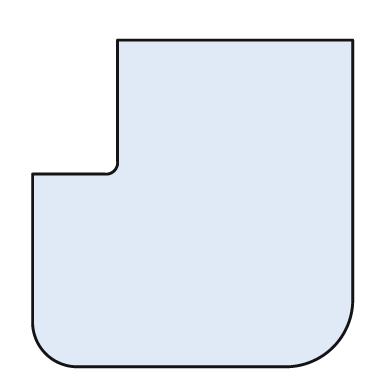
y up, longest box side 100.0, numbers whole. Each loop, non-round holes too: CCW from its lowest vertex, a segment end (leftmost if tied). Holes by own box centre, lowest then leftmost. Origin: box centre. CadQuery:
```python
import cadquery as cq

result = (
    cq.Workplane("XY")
    .moveTo(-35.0, -50.0)
    .lineTo(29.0, -50.0)
    .threePointArc((43.0, -44.0), (49.0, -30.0))
    .lineTo(49.0, 50.0)
    .lineTo(-23.0, 50.0)
    .lineTo(-23.0, 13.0)
    .threePointArc((-24.0, 10.0), (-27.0, 9.0))
    .lineTo(-49.0, 9.0)
    .lineTo(-49.0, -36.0)
    .threePointArc((-45.0, -46.0), (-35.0, -50.0))
    .close()
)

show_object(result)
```